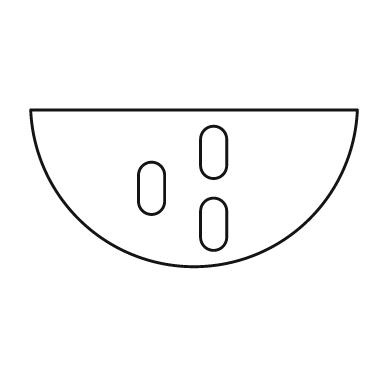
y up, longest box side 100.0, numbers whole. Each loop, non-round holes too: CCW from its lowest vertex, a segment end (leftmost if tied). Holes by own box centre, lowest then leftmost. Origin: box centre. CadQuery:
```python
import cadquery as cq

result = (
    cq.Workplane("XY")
    .moveTo(-50.0, 24.0)
    .threePointArc((0.0, -24.0), (50.0, 24.0))
    .close()
    .moveTo(2.0, -15.0)
    .threePointArc((6.0, -19.0), (10.0, -15.0))
    .lineTo(10.0, -7.0)
    .threePointArc((6.0, -3.0), (2.0, -7.0))
    .close()
    .moveTo(-17.0, -4.0)
    .threePointArc((-13.0, -8.0), (-9.0, -4.0))
    .lineTo(-9.0, 4.0)
    .threePointArc((-13.0, 8.0), (-17.0, 4.0))
    .close()
    .moveTo(2.0, 7.0)
    .threePointArc((6.0, 3.0), (10.0, 7.0))
    .lineTo(10.0, 15.0)
    .threePointArc((6.0, 19.0), (2.0, 15.0))
    .close()
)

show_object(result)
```